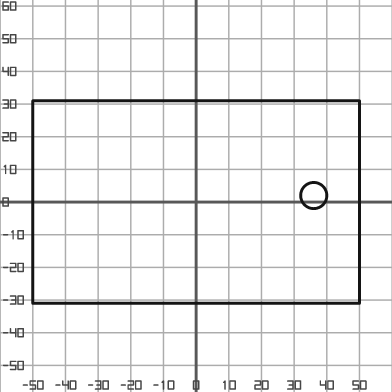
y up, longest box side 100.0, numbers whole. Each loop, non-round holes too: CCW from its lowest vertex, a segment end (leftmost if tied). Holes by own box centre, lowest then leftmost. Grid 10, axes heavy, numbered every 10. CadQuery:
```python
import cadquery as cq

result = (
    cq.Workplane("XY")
    .moveTo(-50.0, -31.0)
    .lineTo(50.0, -31.0)
    .lineTo(50.0, 31.0)
    .lineTo(-50.0, 31.0)
    .close()
    .moveTo(36.0, 2.0)
    .circle(4.0)
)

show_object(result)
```